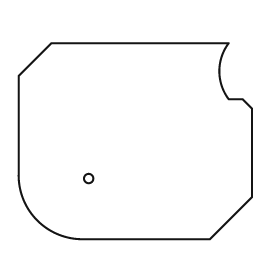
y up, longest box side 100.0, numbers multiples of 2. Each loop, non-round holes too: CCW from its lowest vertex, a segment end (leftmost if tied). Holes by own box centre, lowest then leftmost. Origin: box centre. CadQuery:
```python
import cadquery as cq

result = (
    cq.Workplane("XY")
    .moveTo(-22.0, -42.0)
    .lineTo(32.0, -42.0)
    .lineTo(50.0, -24.0)
    .lineTo(50.0, 14.0)
    .lineTo(46.0, 18.0)
    .lineTo(40.0, 18.0)
    .threePointArc((36.0, 30.0), (40.0, 42.0))
    .lineTo(-36.0, 42.0)
    .lineTo(-50.0, 28.0)
    .lineTo(-50.0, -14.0)
    .threePointArc((-42.0, -34.0), (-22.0, -42.0))
    .close()
    .moveTo(-20.0, -16.0)
    .circle(2.0)
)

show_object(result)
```